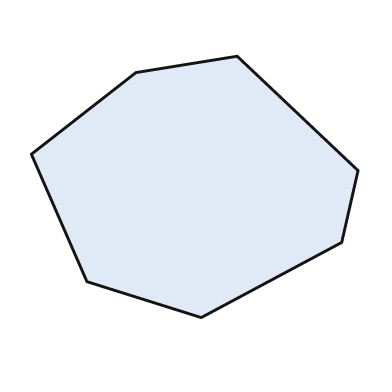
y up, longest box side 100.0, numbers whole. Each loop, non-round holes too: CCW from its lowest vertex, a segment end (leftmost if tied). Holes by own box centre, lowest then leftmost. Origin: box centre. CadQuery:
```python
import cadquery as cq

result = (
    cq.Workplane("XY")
    .moveTo(2.0, -40.0)
    .lineTo(45.0, -17.0)
    .lineTo(50.0, 5.0)
    .lineTo(13.0, 40.0)
    .lineTo(-18.0, 35.0)
    .lineTo(-50.0, 10.0)
    .lineTo(-33.0, -29.0)
    .close()
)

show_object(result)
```